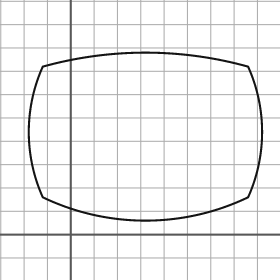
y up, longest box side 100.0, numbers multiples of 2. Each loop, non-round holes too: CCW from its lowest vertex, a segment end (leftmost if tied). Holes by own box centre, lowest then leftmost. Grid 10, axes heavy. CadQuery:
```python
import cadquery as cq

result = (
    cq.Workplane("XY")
    .moveTo(-12.0, 16.0)
    .threePointArc((32.0, 6.0), (76.0, 16.0))
    .threePointArc((82.0, 44.0), (76.0, 72.0))
    .threePointArc((32.0, 78.0), (-12.0, 72.0))
    .threePointArc((-18.0, 44.0), (-12.0, 16.0))
    .close()
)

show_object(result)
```